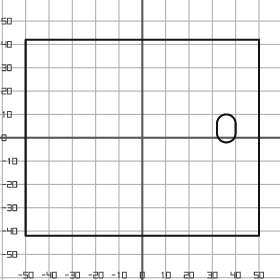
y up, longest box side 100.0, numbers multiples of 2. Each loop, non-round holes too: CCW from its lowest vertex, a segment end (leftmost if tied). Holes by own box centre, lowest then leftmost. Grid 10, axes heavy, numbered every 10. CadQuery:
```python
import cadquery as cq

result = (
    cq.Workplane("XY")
    .moveTo(-50.0, -42.0)
    .lineTo(50.0, -42.0)
    .lineTo(50.0, 42.0)
    .lineTo(-50.0, 42.0)
    .close()
    .moveTo(32.0, 2.0)
    .threePointArc((36.0, -2.0), (40.0, 2.0))
    .lineTo(40.0, 6.0)
    .threePointArc((36.0, 10.0), (32.0, 6.0))
    .close()
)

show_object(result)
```